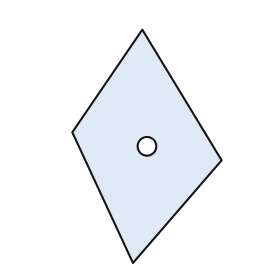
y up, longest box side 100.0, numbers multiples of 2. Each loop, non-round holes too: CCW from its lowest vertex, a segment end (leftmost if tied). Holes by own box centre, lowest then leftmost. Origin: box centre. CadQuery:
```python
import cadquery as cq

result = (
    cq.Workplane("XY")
    .moveTo(-6.0, -50.0)
    .lineTo(32.0, -6.0)
    .lineTo(-2.0, 50.0)
    .lineTo(-32.0, 6.0)
    .close()
    .moveTo(0.0, 0.0)
    .circle(4.0)
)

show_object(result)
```